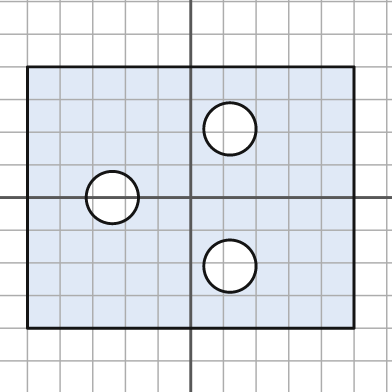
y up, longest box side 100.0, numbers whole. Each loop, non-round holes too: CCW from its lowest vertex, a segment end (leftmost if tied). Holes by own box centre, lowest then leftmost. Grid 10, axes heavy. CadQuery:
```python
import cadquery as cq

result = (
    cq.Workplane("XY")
    .moveTo(-50.0, -40.0)
    .lineTo(50.0, -40.0)
    .lineTo(50.0, 40.0)
    .lineTo(-50.0, 40.0)
    .close()
    .moveTo(12.0, -21.0)
    .circle(8.0)
    .moveTo(-24.0, 0.0)
    .circle(8.0)
    .moveTo(12.0, 21.0)
    .circle(8.0)
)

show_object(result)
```